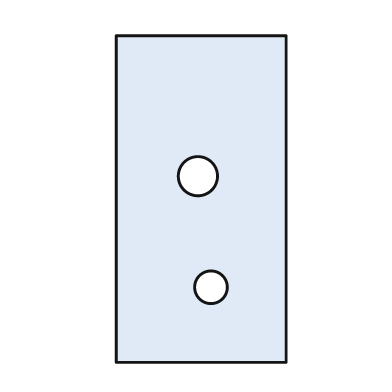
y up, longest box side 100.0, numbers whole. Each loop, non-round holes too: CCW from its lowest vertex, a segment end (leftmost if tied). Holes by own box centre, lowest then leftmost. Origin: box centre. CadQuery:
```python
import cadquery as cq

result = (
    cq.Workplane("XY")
    .moveTo(-26.0, -50.0)
    .lineTo(26.0, -50.0)
    .lineTo(26.0, 50.0)
    .lineTo(-26.0, 50.0)
    .close()
    .moveTo(3.0, -27.0)
    .circle(5.0)
    .moveTo(-1.0, 7.0)
    .circle(6.0)
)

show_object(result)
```